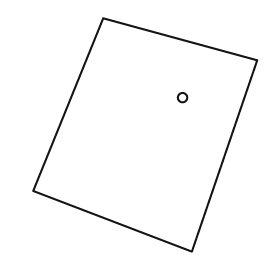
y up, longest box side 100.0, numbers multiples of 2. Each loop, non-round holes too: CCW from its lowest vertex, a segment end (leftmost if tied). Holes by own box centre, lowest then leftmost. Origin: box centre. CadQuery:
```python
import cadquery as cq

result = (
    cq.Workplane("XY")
    .moveTo(20.0, -50.0)
    .lineTo(48.0, 32.0)
    .lineTo(-18.0, 50.0)
    .lineTo(-48.0, -24.0)
    .close()
    .moveTo(16.0, 16.0)
    .circle(2.0)
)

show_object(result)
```